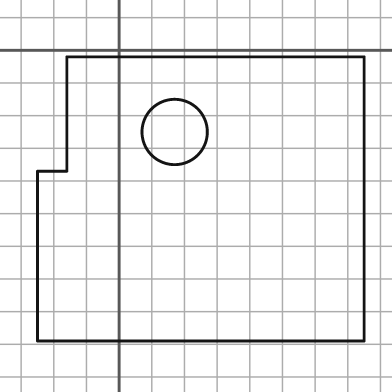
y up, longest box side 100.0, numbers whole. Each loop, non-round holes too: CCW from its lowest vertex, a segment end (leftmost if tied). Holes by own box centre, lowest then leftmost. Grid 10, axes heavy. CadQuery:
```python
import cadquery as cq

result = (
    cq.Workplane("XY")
    .moveTo(-25.0, -89.0)
    .lineTo(75.0, -89.0)
    .lineTo(75.0, -2.0)
    .lineTo(-16.0, -2.0)
    .lineTo(-16.0, -37.0)
    .lineTo(-25.0, -37.0)
    .close()
    .moveTo(17.0, -25.0)
    .circle(10.0)
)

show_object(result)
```